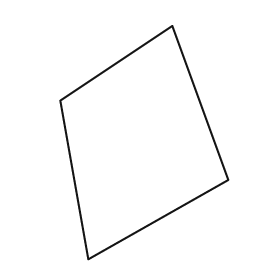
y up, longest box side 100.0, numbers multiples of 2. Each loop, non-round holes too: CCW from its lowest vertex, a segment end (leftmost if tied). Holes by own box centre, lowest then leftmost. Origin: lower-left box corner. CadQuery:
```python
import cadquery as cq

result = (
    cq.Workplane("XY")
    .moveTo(12.0, 0.0)
    .lineTo(72.0, 34.0)
    .lineTo(48.0, 100.0)
    .lineTo(0.0, 68.0)
    .close()
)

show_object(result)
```